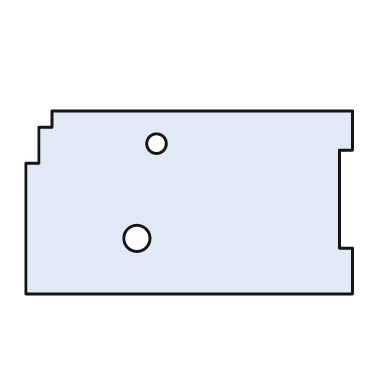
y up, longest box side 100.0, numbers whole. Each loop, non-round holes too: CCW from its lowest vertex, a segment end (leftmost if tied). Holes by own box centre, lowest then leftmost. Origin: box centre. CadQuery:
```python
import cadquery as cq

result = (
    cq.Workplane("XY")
    .moveTo(-50.0, -28.0)
    .lineTo(50.0, -28.0)
    .lineTo(50.0, -14.0)
    .lineTo(46.0, -14.0)
    .lineTo(46.0, 16.0)
    .lineTo(50.0, 16.0)
    .lineTo(50.0, 28.0)
    .lineTo(-42.0, 28.0)
    .lineTo(-42.0, 23.0)
    .lineTo(-46.0, 23.0)
    .lineTo(-46.0, 12.0)
    .lineTo(-50.0, 12.0)
    .close()
    .moveTo(-16.0, -11.0)
    .circle(4.0)
    .moveTo(-10.0, 18.0)
    .circle(3.0)
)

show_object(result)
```